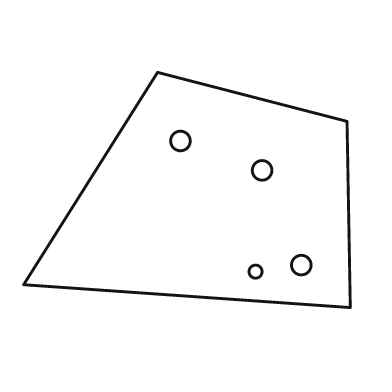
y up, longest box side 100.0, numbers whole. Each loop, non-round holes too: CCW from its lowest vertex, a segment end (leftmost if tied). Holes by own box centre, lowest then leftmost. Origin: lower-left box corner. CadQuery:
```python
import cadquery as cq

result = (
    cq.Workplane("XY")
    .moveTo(100.0, 0.0)
    .lineTo(99.0, 57.0)
    .lineTo(41.0, 72.0)
    .lineTo(0.0, 7.0)
    .close()
    .moveTo(71.0, 11.0)
    .circle(2.0)
    .moveTo(85.0, 13.0)
    .circle(3.0)
    .moveTo(73.0, 42.0)
    .circle(3.0)
    .moveTo(48.0, 51.0)
    .circle(3.0)
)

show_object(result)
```